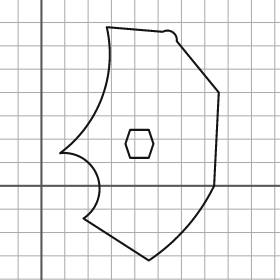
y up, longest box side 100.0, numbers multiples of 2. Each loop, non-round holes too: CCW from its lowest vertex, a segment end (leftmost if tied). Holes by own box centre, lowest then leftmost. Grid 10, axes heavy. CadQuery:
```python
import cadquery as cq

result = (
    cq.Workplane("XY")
    .moveTo(46.0, -32.0)
    .threePointArc((62.0, -18.0), (74.0, 0.0))
    .lineTo(76.0, 40.0)
    .lineTo(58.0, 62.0)
    .threePointArc((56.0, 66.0), (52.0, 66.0))
    .lineTo(28.0, 68.0)
    .threePointArc((26.0, 38.0), (8.0, 14.0))
    .threePointArc((24.0, 4.0), (18.0, -14.0))
    .close()
    .moveTo(38.0, 12.0)
    .lineTo(46.0, 12.0)
    .lineTo(48.0, 18.0)
    .lineTo(46.0, 24.0)
    .lineTo(38.0, 24.0)
    .lineTo(36.0, 18.0)
    .close()
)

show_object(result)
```